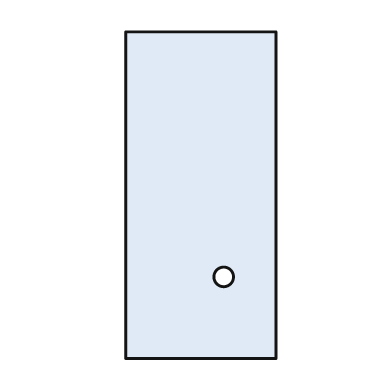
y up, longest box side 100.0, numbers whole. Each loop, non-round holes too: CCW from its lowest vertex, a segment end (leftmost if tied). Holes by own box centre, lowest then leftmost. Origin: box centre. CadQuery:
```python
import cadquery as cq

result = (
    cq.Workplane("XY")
    .moveTo(-23.0, -50.0)
    .lineTo(23.0, -50.0)
    .lineTo(23.0, 50.0)
    .lineTo(-23.0, 50.0)
    .close()
    .moveTo(7.0, -25.0)
    .circle(3.0)
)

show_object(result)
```